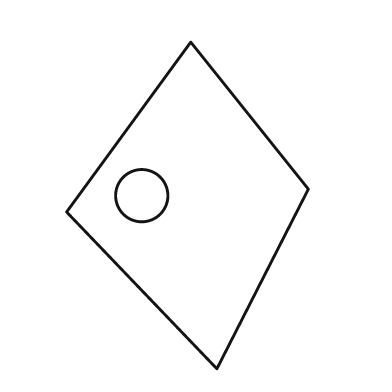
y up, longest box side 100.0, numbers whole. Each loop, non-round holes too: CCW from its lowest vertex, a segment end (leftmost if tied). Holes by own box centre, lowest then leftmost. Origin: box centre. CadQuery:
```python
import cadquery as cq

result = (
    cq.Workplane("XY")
    .moveTo(9.0, -50.0)
    .lineTo(37.0, 5.0)
    .lineTo(1.0, 50.0)
    .lineTo(-37.0, -2.0)
    .close()
    .moveTo(-14.0, 3.0)
    .circle(8.0)
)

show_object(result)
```